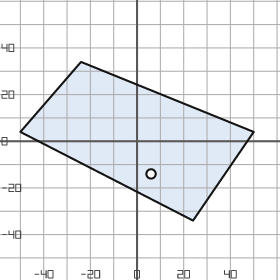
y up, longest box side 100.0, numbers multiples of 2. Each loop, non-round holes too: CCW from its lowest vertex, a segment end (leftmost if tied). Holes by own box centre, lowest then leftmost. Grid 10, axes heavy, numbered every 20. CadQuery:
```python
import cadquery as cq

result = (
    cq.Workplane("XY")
    .moveTo(24.0, -34.0)
    .lineTo(50.0, 4.0)
    .lineTo(-24.0, 34.0)
    .lineTo(-50.0, 4.0)
    .close()
    .moveTo(6.0, -14.0)
    .circle(2.0)
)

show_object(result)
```